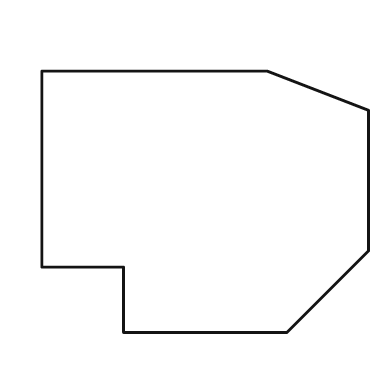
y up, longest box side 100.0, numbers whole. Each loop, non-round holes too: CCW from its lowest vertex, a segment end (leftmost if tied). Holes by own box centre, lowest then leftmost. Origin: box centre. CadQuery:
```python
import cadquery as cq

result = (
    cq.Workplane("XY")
    .moveTo(-25.0, -40.0)
    .lineTo(25.0, -40.0)
    .lineTo(50.0, -15.0)
    .lineTo(50.0, 28.0)
    .lineTo(19.0, 40.0)
    .lineTo(-50.0, 40.0)
    .lineTo(-50.0, -20.0)
    .lineTo(-25.0, -20.0)
    .close()
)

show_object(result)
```